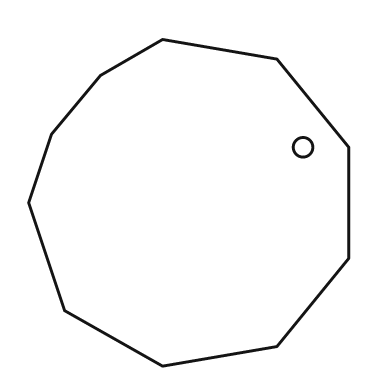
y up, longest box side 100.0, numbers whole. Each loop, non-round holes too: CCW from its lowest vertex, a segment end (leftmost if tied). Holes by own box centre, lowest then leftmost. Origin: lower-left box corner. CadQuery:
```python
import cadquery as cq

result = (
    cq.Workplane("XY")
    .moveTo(41.0, 0.0)
    .lineTo(76.0, 6.0)
    .lineTo(98.0, 33.0)
    .lineTo(98.0, 67.0)
    .lineTo(76.0, 94.0)
    .lineTo(41.0, 100.0)
    .lineTo(22.0, 89.0)
    .lineTo(7.0, 71.0)
    .lineTo(0.0, 50.0)
    .lineTo(11.0, 17.0)
    .close()
    .moveTo(84.0, 67.0)
    .circle(3.0)
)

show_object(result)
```